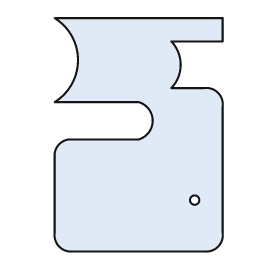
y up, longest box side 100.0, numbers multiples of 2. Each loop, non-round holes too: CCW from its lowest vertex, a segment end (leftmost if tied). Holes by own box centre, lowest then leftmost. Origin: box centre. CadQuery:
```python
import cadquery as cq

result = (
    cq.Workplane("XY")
    .moveTo(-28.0, -50.0)
    .lineTo(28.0, -50.0)
    .threePointArc((34.0, -48.0), (36.0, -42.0))
    .lineTo(36.0, 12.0)
    .threePointArc((34.0, 18.0), (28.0, 20.0))
    .lineTo(14.0, 20.0)
    .threePointArc((18.0, 30.0), (14.0, 40.0))
    .lineTo(36.0, 40.0)
    .lineTo(36.0, 50.0)
    .lineTo(-36.0, 50.0)
    .threePointArc((-26.0, 32.0), (-36.0, 14.0))
    .lineTo(0.0, 14.0)
    .threePointArc((6.0, 6.0), (0.0, -2.0))
    .lineTo(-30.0, -2.0)
    .threePointArc((-34.0, -4.0), (-36.0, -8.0))
    .lineTo(-36.0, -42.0)
    .threePointArc((-34.0, -48.0), (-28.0, -50.0))
    .close()
    .moveTo(24.0, -28.0)
    .circle(2.0)
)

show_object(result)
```